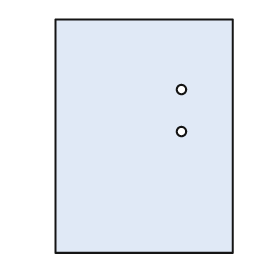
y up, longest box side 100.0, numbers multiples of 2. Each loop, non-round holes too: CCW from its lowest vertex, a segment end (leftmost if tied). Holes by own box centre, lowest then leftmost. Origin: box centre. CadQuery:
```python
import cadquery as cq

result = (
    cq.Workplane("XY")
    .moveTo(-38.0, -50.0)
    .lineTo(38.0, -50.0)
    .lineTo(38.0, 50.0)
    .lineTo(-38.0, 50.0)
    .close()
    .moveTo(16.0, 2.0)
    .circle(2.0)
    .moveTo(16.0, 20.0)
    .circle(2.0)
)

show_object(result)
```